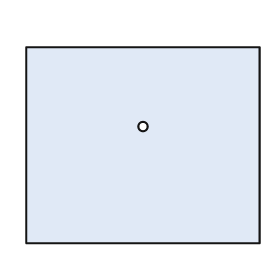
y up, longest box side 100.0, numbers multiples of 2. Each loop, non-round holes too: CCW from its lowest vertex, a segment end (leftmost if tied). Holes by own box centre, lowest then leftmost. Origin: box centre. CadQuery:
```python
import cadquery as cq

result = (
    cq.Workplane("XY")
    .moveTo(-50.0, -42.0)
    .lineTo(50.0, -42.0)
    .lineTo(50.0, 42.0)
    .lineTo(-50.0, 42.0)
    .close()
    .moveTo(0.0, 8.0)
    .circle(2.0)
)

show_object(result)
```